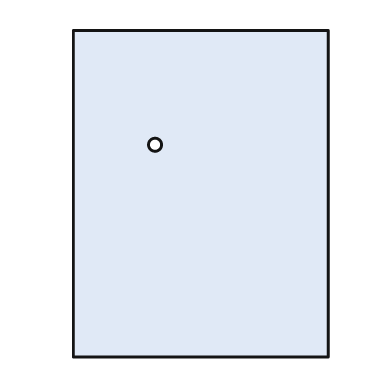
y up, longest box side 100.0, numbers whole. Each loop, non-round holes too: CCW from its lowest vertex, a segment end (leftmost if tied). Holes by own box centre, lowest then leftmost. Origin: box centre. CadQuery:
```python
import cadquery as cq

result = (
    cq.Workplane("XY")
    .moveTo(-39.0, -50.0)
    .lineTo(39.0, -50.0)
    .lineTo(39.0, 50.0)
    .lineTo(-39.0, 50.0)
    .close()
    .moveTo(-14.0, 15.0)
    .circle(2.0)
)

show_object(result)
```